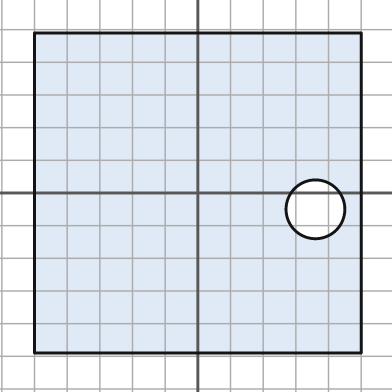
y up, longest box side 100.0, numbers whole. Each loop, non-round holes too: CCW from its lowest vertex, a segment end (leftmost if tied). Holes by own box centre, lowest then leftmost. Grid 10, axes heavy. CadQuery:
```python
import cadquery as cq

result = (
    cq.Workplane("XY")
    .moveTo(-50.0, -49.0)
    .lineTo(50.0, -49.0)
    .lineTo(50.0, 49.0)
    .lineTo(-50.0, 49.0)
    .close()
    .moveTo(36.0, -5.0)
    .circle(9.0)
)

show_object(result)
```